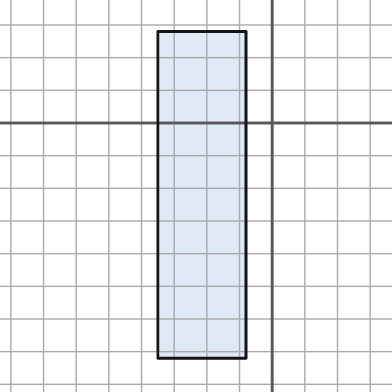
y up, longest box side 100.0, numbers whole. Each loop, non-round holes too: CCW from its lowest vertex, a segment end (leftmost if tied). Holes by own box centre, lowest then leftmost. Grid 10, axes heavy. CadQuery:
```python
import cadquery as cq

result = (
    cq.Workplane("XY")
    .moveTo(-35.0, -72.0)
    .lineTo(-8.0, -72.0)
    .lineTo(-8.0, 28.0)
    .lineTo(-35.0, 28.0)
    .close()
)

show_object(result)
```